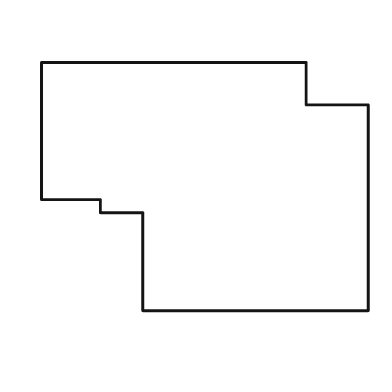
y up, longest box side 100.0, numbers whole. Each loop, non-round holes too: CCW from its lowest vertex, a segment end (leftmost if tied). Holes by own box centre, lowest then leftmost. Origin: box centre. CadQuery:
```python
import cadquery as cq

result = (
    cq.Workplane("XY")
    .moveTo(-19.0, -38.0)
    .lineTo(50.0, -38.0)
    .lineTo(50.0, 25.0)
    .lineTo(31.0, 25.0)
    .lineTo(31.0, 38.0)
    .lineTo(-50.0, 38.0)
    .lineTo(-50.0, -4.0)
    .lineTo(-32.0, -4.0)
    .lineTo(-32.0, -8.0)
    .lineTo(-19.0, -8.0)
    .close()
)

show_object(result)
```